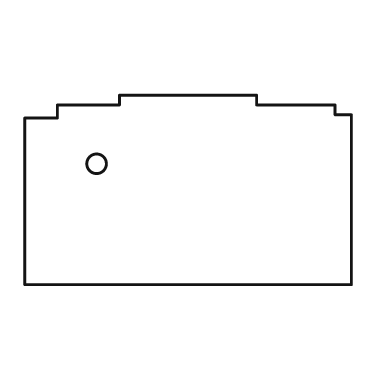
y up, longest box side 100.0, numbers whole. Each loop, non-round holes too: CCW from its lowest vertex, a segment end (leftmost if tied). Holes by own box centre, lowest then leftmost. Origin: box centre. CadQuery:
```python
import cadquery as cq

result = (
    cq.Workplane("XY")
    .moveTo(-50.0, -29.0)
    .lineTo(50.0, -29.0)
    .lineTo(50.0, 23.0)
    .lineTo(45.0, 23.0)
    .lineTo(45.0, 26.0)
    .lineTo(21.0, 26.0)
    .lineTo(21.0, 29.0)
    .lineTo(-21.0, 29.0)
    .lineTo(-21.0, 26.0)
    .lineTo(-40.0, 26.0)
    .lineTo(-40.0, 22.0)
    .lineTo(-50.0, 22.0)
    .close()
    .moveTo(-28.0, 8.0)
    .circle(3.0)
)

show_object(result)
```